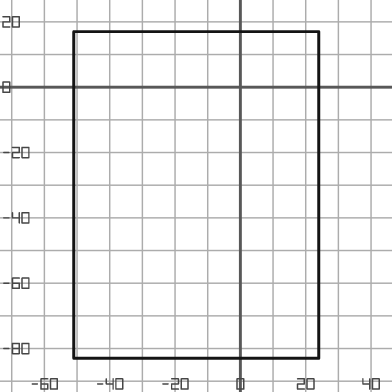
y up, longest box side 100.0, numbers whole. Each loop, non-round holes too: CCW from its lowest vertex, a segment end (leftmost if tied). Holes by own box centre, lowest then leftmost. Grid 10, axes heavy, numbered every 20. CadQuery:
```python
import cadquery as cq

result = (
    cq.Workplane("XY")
    .moveTo(-51.0, -83.0)
    .lineTo(24.0, -83.0)
    .lineTo(24.0, 17.0)
    .lineTo(-51.0, 17.0)
    .close()
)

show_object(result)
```